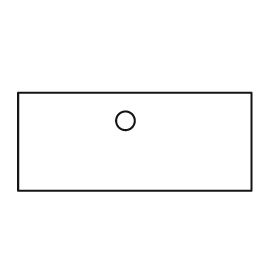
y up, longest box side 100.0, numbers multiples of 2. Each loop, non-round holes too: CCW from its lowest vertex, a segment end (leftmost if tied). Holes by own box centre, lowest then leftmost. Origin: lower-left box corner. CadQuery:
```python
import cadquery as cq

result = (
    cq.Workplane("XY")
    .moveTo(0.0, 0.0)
    .lineTo(100.0, 0.0)
    .lineTo(100.0, 42.0)
    .lineTo(0.0, 42.0)
    .close()
    .moveTo(46.0, 30.0)
    .circle(4.0)
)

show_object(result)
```